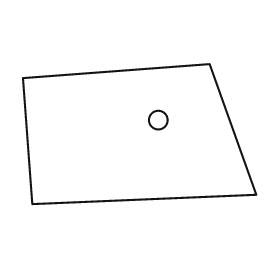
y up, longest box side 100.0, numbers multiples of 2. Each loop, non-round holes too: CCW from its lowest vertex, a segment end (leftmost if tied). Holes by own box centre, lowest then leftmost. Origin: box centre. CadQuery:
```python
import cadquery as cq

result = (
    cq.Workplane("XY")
    .moveTo(-46.0, -30.0)
    .lineTo(50.0, -26.0)
    .lineTo(30.0, 30.0)
    .lineTo(-50.0, 24.0)
    .close()
    .moveTo(8.0, 6.0)
    .circle(4.0)
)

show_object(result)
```